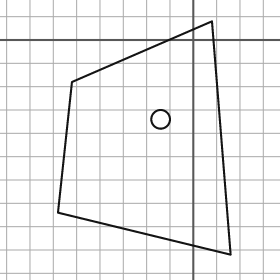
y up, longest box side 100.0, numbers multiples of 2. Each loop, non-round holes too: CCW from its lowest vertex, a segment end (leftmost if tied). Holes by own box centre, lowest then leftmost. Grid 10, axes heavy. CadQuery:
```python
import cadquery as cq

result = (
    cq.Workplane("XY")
    .moveTo(16.0, -92.0)
    .lineTo(8.0, 8.0)
    .lineTo(-52.0, -18.0)
    .lineTo(-58.0, -74.0)
    .close()
    .moveTo(-14.0, -34.0)
    .circle(4.0)
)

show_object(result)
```